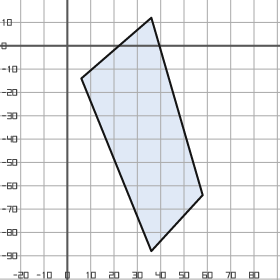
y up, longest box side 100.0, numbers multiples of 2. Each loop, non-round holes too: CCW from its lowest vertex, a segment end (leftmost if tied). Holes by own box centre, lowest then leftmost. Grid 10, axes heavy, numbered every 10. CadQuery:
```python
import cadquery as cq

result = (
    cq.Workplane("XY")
    .moveTo(36.0, -88.0)
    .lineTo(58.0, -64.0)
    .lineTo(36.0, 12.0)
    .lineTo(6.0, -14.0)
    .close()
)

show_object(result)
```